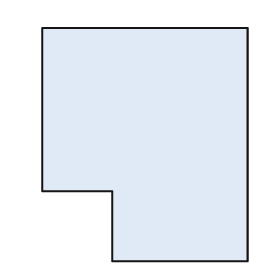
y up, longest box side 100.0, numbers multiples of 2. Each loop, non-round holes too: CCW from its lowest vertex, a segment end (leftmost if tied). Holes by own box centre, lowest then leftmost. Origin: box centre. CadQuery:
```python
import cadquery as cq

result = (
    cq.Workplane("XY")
    .moveTo(-14.0, -50.0)
    .lineTo(44.0, -50.0)
    .lineTo(44.0, 50.0)
    .lineTo(-44.0, 50.0)
    .lineTo(-44.0, -20.0)
    .lineTo(-14.0, -20.0)
    .close()
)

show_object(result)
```